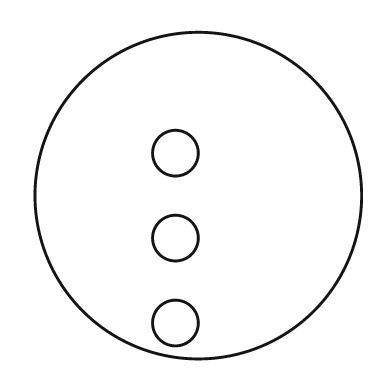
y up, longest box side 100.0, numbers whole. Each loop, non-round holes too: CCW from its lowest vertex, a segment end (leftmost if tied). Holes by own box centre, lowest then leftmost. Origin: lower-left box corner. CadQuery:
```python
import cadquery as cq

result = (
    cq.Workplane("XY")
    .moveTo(50.0, 50.0)
    .circle(50.0)
    .moveTo(43.0, 11.0)
    .circle(7.0)
    .moveTo(43.0, 37.0)
    .circle(7.0)
    .moveTo(43.0, 63.0)
    .circle(7.0)
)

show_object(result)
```